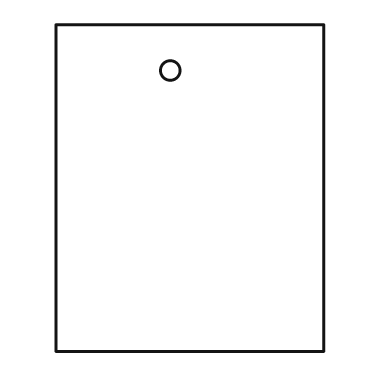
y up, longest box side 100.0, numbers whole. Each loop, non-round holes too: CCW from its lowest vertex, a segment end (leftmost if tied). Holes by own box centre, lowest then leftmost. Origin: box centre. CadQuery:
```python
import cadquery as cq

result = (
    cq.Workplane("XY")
    .moveTo(-41.0, -50.0)
    .lineTo(41.0, -50.0)
    .lineTo(41.0, 50.0)
    .lineTo(-41.0, 50.0)
    .close()
    .moveTo(-6.0, 36.0)
    .circle(3.0)
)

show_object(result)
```